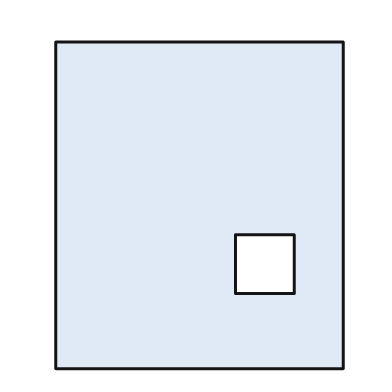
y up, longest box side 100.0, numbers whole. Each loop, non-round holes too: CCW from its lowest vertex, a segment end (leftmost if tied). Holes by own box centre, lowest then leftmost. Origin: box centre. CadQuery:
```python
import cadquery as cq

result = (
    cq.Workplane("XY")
    .moveTo(-44.0, -50.0)
    .lineTo(44.0, -50.0)
    .lineTo(44.0, 50.0)
    .lineTo(-44.0, 50.0)
    .close()
    .moveTo(11.0, -27.0)
    .lineTo(29.0, -27.0)
    .lineTo(29.0, -9.0)
    .lineTo(11.0, -9.0)
    .close()
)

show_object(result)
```